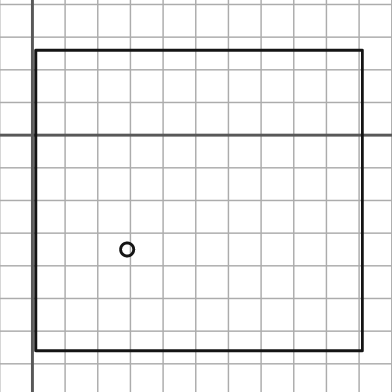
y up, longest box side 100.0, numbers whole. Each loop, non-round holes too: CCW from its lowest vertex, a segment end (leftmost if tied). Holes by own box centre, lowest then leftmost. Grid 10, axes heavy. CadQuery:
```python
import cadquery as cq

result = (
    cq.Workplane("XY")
    .moveTo(1.0, -66.0)
    .lineTo(101.0, -66.0)
    .lineTo(101.0, 26.0)
    .lineTo(1.0, 26.0)
    .close()
    .moveTo(29.0, -35.0)
    .circle(2.0)
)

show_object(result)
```